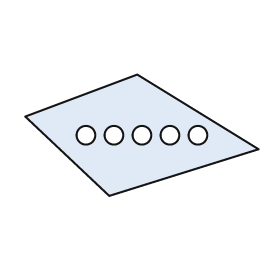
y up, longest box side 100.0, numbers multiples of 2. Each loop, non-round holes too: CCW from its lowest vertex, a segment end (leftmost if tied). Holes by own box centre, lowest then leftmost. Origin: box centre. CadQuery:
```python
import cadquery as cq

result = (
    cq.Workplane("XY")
    .moveTo(-14.0, -26.0)
    .lineTo(50.0, -6.0)
    .lineTo(-2.0, 26.0)
    .lineTo(-50.0, 8.0)
    .close()
    .moveTo(-24.0, 0.0)
    .circle(4.0)
    .moveTo(-12.0, 0.0)
    .circle(4.0)
    .moveTo(0.0, 0.0)
    .circle(4.0)
    .moveTo(12.0, 0.0)
    .circle(4.0)
    .moveTo(24.0, 0.0)
    .circle(4.0)
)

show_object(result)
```